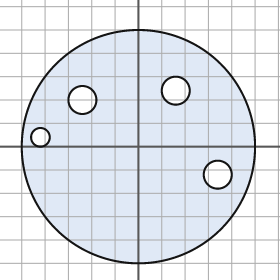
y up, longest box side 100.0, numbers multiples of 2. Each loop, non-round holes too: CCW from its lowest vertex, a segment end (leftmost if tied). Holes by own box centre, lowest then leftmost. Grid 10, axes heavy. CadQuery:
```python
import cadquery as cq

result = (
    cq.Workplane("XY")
    .moveTo(0.0, 0.0)
    .circle(50.0)
    .moveTo(34.0, -12.0)
    .circle(6.0)
    .moveTo(-42.0, 4.0)
    .circle(4.0)
    .moveTo(-24.0, 20.0)
    .circle(6.0)
    .moveTo(16.0, 24.0)
    .circle(6.0)
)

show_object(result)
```